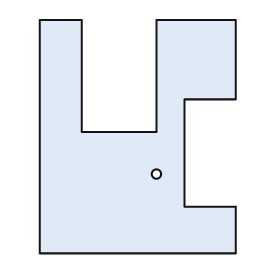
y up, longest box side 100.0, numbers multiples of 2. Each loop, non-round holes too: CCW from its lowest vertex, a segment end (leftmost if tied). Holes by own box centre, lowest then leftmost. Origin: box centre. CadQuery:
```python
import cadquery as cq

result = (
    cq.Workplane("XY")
    .moveTo(-42.0, -50.0)
    .lineTo(42.0, -50.0)
    .lineTo(42.0, -30.0)
    .lineTo(20.0, -30.0)
    .lineTo(20.0, 16.0)
    .lineTo(42.0, 16.0)
    .lineTo(42.0, 50.0)
    .lineTo(8.0, 50.0)
    .lineTo(8.0, 2.0)
    .lineTo(-24.0, 2.0)
    .lineTo(-24.0, 50.0)
    .lineTo(-42.0, 50.0)
    .close()
    .moveTo(8.0, -16.0)
    .circle(2.0)
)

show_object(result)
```